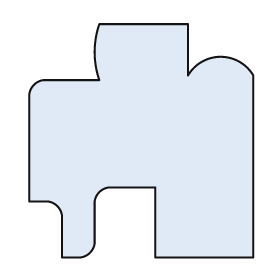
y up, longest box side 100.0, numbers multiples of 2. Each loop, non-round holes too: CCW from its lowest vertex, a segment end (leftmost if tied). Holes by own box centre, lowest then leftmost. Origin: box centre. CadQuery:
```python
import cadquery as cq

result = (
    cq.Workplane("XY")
    .moveTo(-34.0, -50.0)
    .lineTo(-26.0, -50.0)
    .threePointArc((-22.0, -48.0), (-20.0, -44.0))
    .lineTo(-20.0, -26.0)
    .threePointArc((-18.0, -22.0), (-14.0, -20.0))
    .lineTo(6.0, -20.0)
    .lineTo(6.0, -50.0)
    .lineTo(48.0, -50.0)
    .lineTo(48.0, 28.0)
    .threePointArc((34.0, 36.0), (20.0, 28.0))
    .lineTo(20.0, 50.0)
    .lineTo(-18.0, 50.0)
    .threePointArc((-20.0, 38.0), (-18.0, 26.0))
    .lineTo(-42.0, 26.0)
    .threePointArc((-46.0, 24.0), (-48.0, 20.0))
    .lineTo(-48.0, -26.0)
    .lineTo(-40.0, -26.0)
    .threePointArc((-36.0, -28.0), (-34.0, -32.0))
    .close()
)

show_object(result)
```